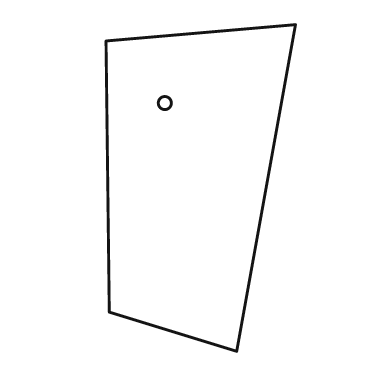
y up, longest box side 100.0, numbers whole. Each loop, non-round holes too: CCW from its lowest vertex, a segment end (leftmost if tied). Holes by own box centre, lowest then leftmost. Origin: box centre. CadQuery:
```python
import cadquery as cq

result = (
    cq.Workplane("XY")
    .moveTo(11.0, -50.0)
    .lineTo(29.0, 50.0)
    .lineTo(-29.0, 45.0)
    .lineTo(-28.0, -38.0)
    .close()
    .moveTo(-11.0, 26.0)
    .circle(2.0)
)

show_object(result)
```